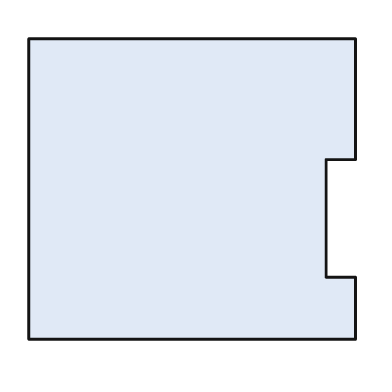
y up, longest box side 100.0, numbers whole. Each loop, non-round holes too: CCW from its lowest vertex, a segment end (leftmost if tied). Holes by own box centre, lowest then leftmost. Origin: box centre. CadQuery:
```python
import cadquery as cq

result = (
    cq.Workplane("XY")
    .moveTo(-50.0, -46.0)
    .lineTo(50.0, -46.0)
    .lineTo(50.0, -27.0)
    .lineTo(41.0, -27.0)
    .lineTo(41.0, 9.0)
    .lineTo(50.0, 9.0)
    .lineTo(50.0, 46.0)
    .lineTo(-50.0, 46.0)
    .close()
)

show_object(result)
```